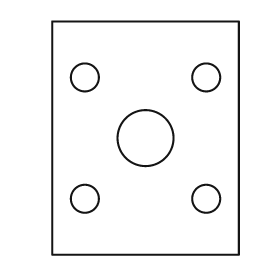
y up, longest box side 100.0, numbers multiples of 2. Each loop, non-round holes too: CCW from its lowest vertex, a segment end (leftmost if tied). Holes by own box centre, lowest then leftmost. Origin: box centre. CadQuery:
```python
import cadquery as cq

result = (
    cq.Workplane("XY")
    .moveTo(-40.0, -50.0)
    .lineTo(40.0, -50.0)
    .lineTo(40.0, 50.0)
    .lineTo(-40.0, 50.0)
    .close()
    .moveTo(-26.0, -26.0)
    .circle(6.0)
    .moveTo(26.0, -26.0)
    .circle(6.0)
    .moveTo(0.0, 0.0)
    .circle(12.0)
    .moveTo(-26.0, 26.0)
    .circle(6.0)
    .moveTo(26.0, 26.0)
    .circle(6.0)
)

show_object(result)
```